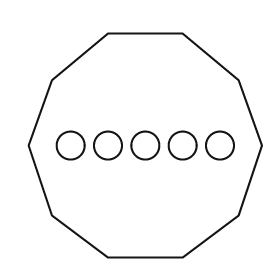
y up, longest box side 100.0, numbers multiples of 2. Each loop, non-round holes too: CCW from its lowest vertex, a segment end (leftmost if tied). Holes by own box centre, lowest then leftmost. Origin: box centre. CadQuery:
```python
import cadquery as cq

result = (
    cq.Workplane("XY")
    .moveTo(-16.0, -48.0)
    .lineTo(16.0, -48.0)
    .lineTo(40.0, -30.0)
    .lineTo(50.0, 0.0)
    .lineTo(40.0, 28.0)
    .lineTo(16.0, 48.0)
    .lineTo(-16.0, 48.0)
    .lineTo(-40.0, 28.0)
    .lineTo(-50.0, 0.0)
    .lineTo(-40.0, -30.0)
    .close()
    .moveTo(-32.0, 0.0)
    .circle(6.0)
    .moveTo(-16.0, 0.0)
    .circle(6.0)
    .moveTo(0.0, 0.0)
    .circle(6.0)
    .moveTo(16.0, 0.0)
    .circle(6.0)
    .moveTo(32.0, 0.0)
    .circle(6.0)
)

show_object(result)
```